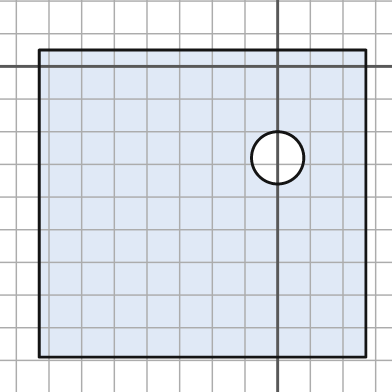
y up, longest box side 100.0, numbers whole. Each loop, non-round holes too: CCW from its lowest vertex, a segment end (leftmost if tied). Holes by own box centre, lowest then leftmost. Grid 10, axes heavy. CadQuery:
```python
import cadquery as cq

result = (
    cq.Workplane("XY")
    .moveTo(-73.0, -89.0)
    .lineTo(27.0, -89.0)
    .lineTo(27.0, 5.0)
    .lineTo(-73.0, 5.0)
    .close()
    .moveTo(0.0, -28.0)
    .circle(8.0)
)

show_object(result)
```